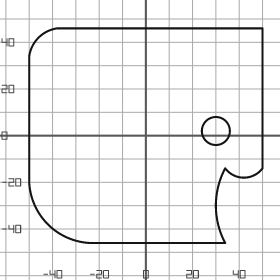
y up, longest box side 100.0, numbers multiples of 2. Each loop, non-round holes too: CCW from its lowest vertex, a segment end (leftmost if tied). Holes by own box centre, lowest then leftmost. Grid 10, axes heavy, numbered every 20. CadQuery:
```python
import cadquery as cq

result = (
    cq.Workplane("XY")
    .moveTo(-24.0, -46.0)
    .lineTo(34.0, -46.0)
    .threePointArc((30.0, -30.0), (34.0, -14.0))
    .threePointArc((42.0, -18.0), (50.0, -14.0))
    .lineTo(50.0, 46.0)
    .lineTo(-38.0, 46.0)
    .threePointArc((-46.0, 42.0), (-50.0, 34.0))
    .lineTo(-50.0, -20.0)
    .threePointArc((-42.0, -38.0), (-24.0, -46.0))
    .close()
    .moveTo(30.0, 2.0)
    .circle(6.0)
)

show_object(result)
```